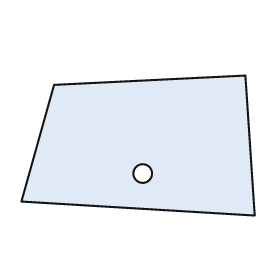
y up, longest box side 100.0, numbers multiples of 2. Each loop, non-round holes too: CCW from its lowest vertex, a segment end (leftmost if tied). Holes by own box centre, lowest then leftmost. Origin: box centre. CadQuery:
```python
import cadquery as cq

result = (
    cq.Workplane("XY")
    .moveTo(50.0, -30.0)
    .lineTo(46.0, 30.0)
    .lineTo(-36.0, 26.0)
    .lineTo(-50.0, -24.0)
    .close()
    .moveTo(2.0, -12.0)
    .circle(4.0)
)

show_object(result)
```